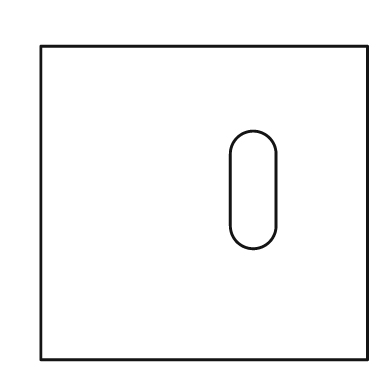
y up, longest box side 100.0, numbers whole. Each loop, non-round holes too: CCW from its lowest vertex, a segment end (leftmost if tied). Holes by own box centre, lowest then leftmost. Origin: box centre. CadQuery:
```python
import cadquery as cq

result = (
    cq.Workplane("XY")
    .moveTo(-50.0, -48.0)
    .lineTo(50.0, -48.0)
    .lineTo(50.0, 48.0)
    .lineTo(-50.0, 48.0)
    .close()
    .moveTo(8.0, -7.0)
    .threePointArc((15.0, -14.0), (22.0, -7.0))
    .lineTo(22.0, 15.0)
    .threePointArc((15.0, 22.0), (8.0, 15.0))
    .close()
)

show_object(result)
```